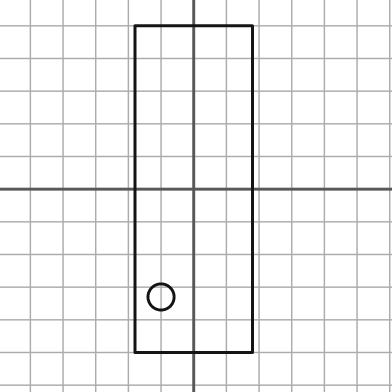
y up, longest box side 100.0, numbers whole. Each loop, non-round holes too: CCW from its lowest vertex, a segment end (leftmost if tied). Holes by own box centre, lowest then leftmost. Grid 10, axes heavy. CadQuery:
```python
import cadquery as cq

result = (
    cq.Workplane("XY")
    .moveTo(-18.0, -50.0)
    .lineTo(18.0, -50.0)
    .lineTo(18.0, 50.0)
    .lineTo(-18.0, 50.0)
    .close()
    .moveTo(-10.0, -33.0)
    .circle(4.0)
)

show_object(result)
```